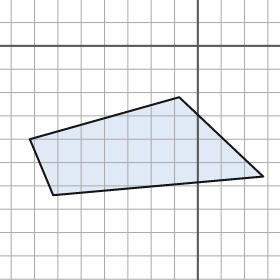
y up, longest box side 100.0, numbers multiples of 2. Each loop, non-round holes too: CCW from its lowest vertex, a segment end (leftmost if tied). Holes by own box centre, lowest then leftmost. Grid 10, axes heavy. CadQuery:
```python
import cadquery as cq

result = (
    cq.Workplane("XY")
    .moveTo(-62.0, -64.0)
    .lineTo(28.0, -56.0)
    .lineTo(-8.0, -22.0)
    .lineTo(-72.0, -40.0)
    .close()
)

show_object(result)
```